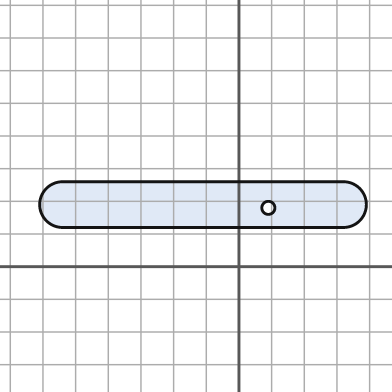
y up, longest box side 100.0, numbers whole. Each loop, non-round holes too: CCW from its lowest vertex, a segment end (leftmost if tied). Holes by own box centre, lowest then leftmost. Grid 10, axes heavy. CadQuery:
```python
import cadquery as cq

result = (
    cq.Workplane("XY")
    .moveTo(-54.0, 12.0)
    .lineTo(32.0, 12.0)
    .threePointArc((39.0, 19.0), (32.0, 26.0))
    .lineTo(-54.0, 26.0)
    .threePointArc((-61.0, 19.0), (-54.0, 12.0))
    .close()
    .moveTo(9.0, 18.0)
    .circle(2.0)
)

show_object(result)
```